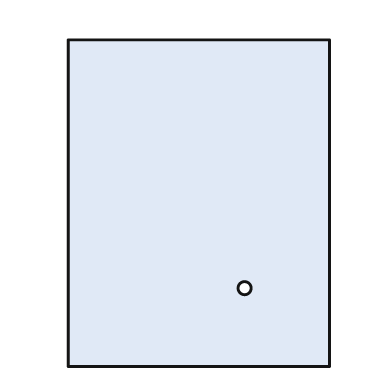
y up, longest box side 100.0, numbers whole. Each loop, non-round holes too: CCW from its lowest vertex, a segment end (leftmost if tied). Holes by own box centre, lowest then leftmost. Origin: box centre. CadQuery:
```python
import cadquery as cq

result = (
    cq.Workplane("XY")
    .moveTo(-40.0, -50.0)
    .lineTo(40.0, -50.0)
    .lineTo(40.0, 50.0)
    .lineTo(-40.0, 50.0)
    .close()
    .moveTo(14.0, -26.0)
    .circle(2.0)
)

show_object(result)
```